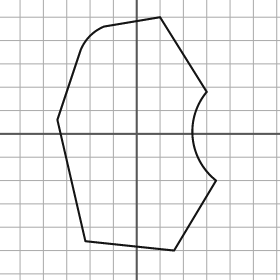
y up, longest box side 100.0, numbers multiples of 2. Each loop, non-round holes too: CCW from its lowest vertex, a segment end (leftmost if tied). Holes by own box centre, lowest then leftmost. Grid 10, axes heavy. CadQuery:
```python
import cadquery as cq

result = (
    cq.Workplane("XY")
    .moveTo(16.0, -50.0)
    .lineTo(34.0, -20.0)
    .threePointArc((24.0, -2.0), (30.0, 18.0))
    .lineTo(10.0, 50.0)
    .lineTo(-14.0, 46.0)
    .threePointArc((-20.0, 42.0), (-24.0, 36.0))
    .lineTo(-34.0, 6.0)
    .lineTo(-22.0, -46.0)
    .close()
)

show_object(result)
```